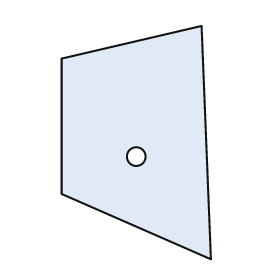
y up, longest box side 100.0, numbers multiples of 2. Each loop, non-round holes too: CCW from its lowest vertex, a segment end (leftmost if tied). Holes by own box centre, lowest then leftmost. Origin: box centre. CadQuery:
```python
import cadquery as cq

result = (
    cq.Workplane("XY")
    .moveTo(32.0, -50.0)
    .lineTo(28.0, 50.0)
    .lineTo(-32.0, 36.0)
    .lineTo(-32.0, -22.0)
    .close()
    .moveTo(0.0, -6.0)
    .circle(4.0)
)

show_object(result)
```